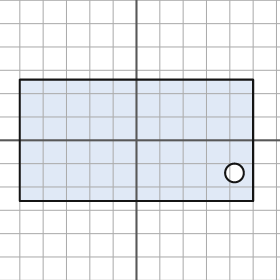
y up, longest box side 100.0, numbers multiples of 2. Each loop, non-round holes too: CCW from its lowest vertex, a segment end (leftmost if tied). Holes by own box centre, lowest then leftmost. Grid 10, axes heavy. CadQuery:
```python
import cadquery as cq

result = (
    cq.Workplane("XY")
    .moveTo(-50.0, -26.0)
    .lineTo(50.0, -26.0)
    .lineTo(50.0, 26.0)
    .lineTo(-50.0, 26.0)
    .close()
    .moveTo(42.0, -14.0)
    .circle(4.0)
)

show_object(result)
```